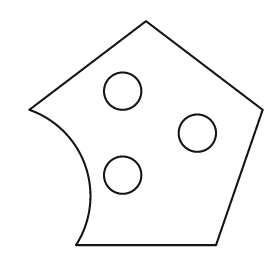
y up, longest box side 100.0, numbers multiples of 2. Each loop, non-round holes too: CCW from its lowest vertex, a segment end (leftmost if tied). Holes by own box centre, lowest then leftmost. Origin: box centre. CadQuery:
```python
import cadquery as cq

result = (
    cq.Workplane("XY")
    .moveTo(-30.0, -48.0)
    .lineTo(30.0, -48.0)
    .lineTo(50.0, 10.0)
    .lineTo(0.0, 48.0)
    .lineTo(-50.0, 10.0)
    .threePointArc((-26.0, -14.0), (-30.0, -48.0))
    .close()
    .moveTo(-10.0, -18.0)
    .circle(8.0)
    .moveTo(22.0, 0.0)
    .circle(8.0)
    .moveTo(-10.0, 18.0)
    .circle(8.0)
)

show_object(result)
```